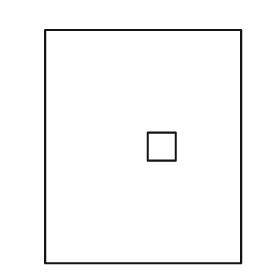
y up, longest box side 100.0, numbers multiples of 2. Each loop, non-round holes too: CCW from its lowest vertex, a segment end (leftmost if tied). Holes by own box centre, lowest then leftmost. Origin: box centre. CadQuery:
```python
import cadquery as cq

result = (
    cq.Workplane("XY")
    .moveTo(-42.0, -50.0)
    .lineTo(42.0, -50.0)
    .lineTo(42.0, 50.0)
    .lineTo(-42.0, 50.0)
    .close()
    .moveTo(2.0, -6.0)
    .lineTo(14.0, -6.0)
    .lineTo(14.0, 6.0)
    .lineTo(2.0, 6.0)
    .close()
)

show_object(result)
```